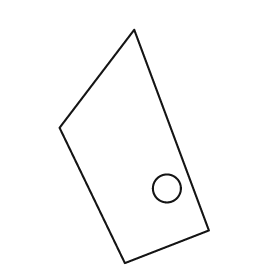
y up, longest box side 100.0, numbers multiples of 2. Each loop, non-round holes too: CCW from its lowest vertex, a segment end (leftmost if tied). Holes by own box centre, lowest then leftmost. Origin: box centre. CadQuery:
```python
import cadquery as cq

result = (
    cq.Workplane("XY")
    .moveTo(-4.0, -50.0)
    .lineTo(32.0, -36.0)
    .lineTo(0.0, 50.0)
    .lineTo(-32.0, 8.0)
    .close()
    .moveTo(14.0, -18.0)
    .circle(6.0)
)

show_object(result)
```